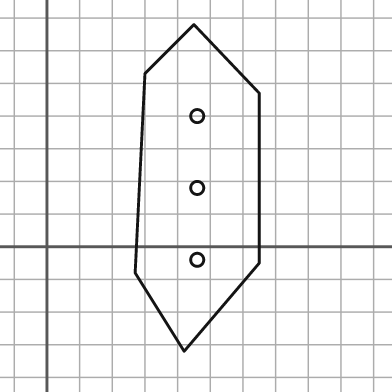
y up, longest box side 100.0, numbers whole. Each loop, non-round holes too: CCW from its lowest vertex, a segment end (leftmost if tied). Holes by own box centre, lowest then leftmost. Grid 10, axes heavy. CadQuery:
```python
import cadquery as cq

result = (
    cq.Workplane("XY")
    .moveTo(42.0, -32.0)
    .lineTo(65.0, -5.0)
    .lineTo(65.0, 47.0)
    .lineTo(45.0, 68.0)
    .lineTo(30.0, 53.0)
    .lineTo(27.0, -8.0)
    .close()
    .moveTo(46.0, -4.0)
    .circle(2.0)
    .moveTo(46.0, 18.0)
    .circle(2.0)
    .moveTo(46.0, 40.0)
    .circle(2.0)
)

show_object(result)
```